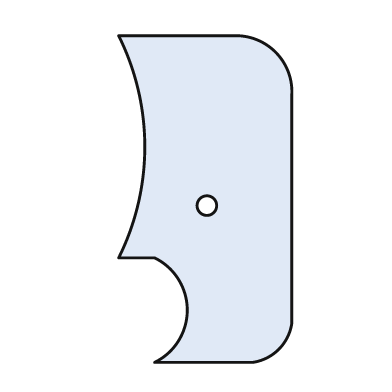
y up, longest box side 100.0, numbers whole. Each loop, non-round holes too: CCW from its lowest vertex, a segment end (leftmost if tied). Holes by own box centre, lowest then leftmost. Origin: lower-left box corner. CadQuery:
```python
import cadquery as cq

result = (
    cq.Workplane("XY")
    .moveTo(11.0, 0.0)
    .lineTo(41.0, 0.0)
    .threePointArc((49.0, 4.0), (53.0, 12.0))
    .lineTo(53.0, 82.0)
    .threePointArc((48.0, 95.0), (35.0, 100.0))
    .lineTo(0.0, 100.0)
    .threePointArc((8.0, 66.0), (0.0, 32.0))
    .lineTo(11.0, 32.0)
    .threePointArc((21.0, 16.0), (11.0, 0.0))
    .close()
    .moveTo(27.0, 48.0)
    .circle(3.0)
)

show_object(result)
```